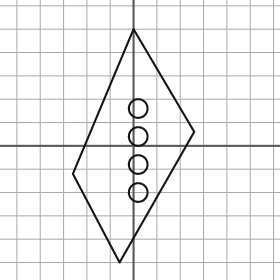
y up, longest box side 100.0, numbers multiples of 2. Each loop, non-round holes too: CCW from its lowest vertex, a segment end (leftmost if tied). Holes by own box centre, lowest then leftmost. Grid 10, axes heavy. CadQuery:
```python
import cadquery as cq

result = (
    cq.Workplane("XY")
    .moveTo(-6.0, -50.0)
    .lineTo(26.0, 6.0)
    .lineTo(0.0, 50.0)
    .lineTo(-26.0, -12.0)
    .close()
    .moveTo(2.0, -20.0)
    .circle(4.0)
    .moveTo(2.0, -8.0)
    .circle(4.0)
    .moveTo(2.0, 4.0)
    .circle(4.0)
    .moveTo(2.0, 16.0)
    .circle(4.0)
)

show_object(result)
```